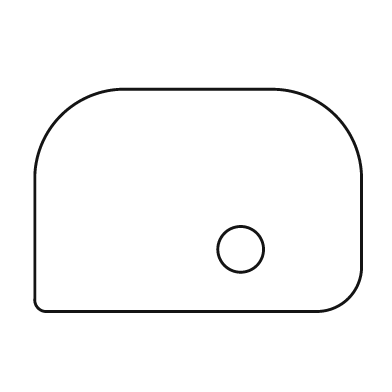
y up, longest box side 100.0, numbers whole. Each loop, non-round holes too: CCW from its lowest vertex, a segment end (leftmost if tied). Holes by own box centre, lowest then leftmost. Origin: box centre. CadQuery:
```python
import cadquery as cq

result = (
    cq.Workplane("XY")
    .moveTo(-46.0, -34.0)
    .lineTo(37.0, -34.0)
    .threePointArc((46.0, -30.0), (50.0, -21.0))
    .lineTo(50.0, 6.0)
    .threePointArc((42.0, 26.0), (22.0, 34.0))
    .lineTo(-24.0, 34.0)
    .threePointArc((-42.0, 26.0), (-50.0, 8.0))
    .lineTo(-50.0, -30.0)
    .threePointArc((-49.0, -33.0), (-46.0, -34.0))
    .close()
    .moveTo(13.0, -15.0)
    .circle(7.0)
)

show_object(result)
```